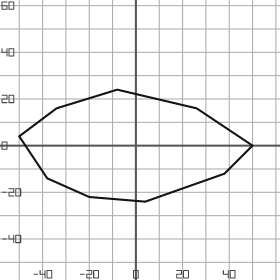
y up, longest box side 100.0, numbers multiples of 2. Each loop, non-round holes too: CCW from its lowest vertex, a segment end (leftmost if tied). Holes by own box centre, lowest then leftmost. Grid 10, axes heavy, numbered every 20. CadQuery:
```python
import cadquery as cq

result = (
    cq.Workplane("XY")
    .moveTo(4.0, -24.0)
    .lineTo(38.0, -12.0)
    .lineTo(50.0, 0.0)
    .lineTo(26.0, 16.0)
    .lineTo(-8.0, 24.0)
    .lineTo(-34.0, 16.0)
    .lineTo(-50.0, 4.0)
    .lineTo(-38.0, -14.0)
    .lineTo(-20.0, -22.0)
    .close()
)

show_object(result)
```